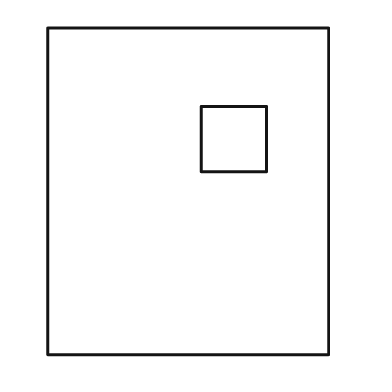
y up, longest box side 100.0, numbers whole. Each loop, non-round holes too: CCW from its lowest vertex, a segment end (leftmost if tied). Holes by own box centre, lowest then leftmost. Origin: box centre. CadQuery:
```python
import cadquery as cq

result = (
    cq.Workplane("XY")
    .moveTo(-43.0, -50.0)
    .lineTo(43.0, -50.0)
    .lineTo(43.0, 50.0)
    .lineTo(-43.0, 50.0)
    .close()
    .moveTo(4.0, 6.0)
    .lineTo(24.0, 6.0)
    .lineTo(24.0, 26.0)
    .lineTo(4.0, 26.0)
    .close()
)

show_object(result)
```